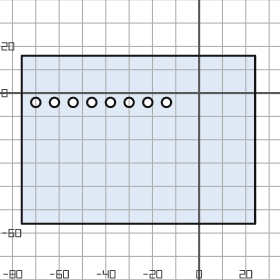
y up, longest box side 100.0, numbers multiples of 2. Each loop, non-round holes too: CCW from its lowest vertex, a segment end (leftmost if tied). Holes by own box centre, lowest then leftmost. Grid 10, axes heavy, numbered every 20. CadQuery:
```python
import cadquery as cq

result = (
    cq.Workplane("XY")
    .moveTo(-76.0, -56.0)
    .lineTo(24.0, -56.0)
    .lineTo(24.0, 16.0)
    .lineTo(-76.0, 16.0)
    .close()
    .moveTo(-70.0, -4.0)
    .circle(2.0)
    .moveTo(-62.0, -4.0)
    .circle(2.0)
    .moveTo(-54.0, -4.0)
    .circle(2.0)
    .moveTo(-46.0, -4.0)
    .circle(2.0)
    .moveTo(-38.0, -4.0)
    .circle(2.0)
    .moveTo(-30.0, -4.0)
    .circle(2.0)
    .moveTo(-22.0, -4.0)
    .circle(2.0)
    .moveTo(-14.0, -4.0)
    .circle(2.0)
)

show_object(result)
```